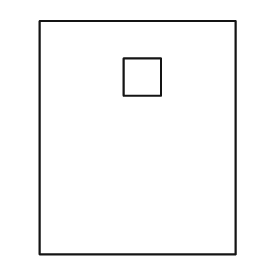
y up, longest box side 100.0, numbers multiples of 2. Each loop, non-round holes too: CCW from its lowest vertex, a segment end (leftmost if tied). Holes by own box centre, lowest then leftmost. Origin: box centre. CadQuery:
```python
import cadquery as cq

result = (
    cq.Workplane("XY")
    .moveTo(-42.0, -50.0)
    .lineTo(42.0, -50.0)
    .lineTo(42.0, 50.0)
    .lineTo(-42.0, 50.0)
    .close()
    .moveTo(-6.0, 18.0)
    .lineTo(10.0, 18.0)
    .lineTo(10.0, 34.0)
    .lineTo(-6.0, 34.0)
    .close()
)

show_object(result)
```